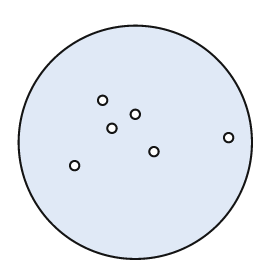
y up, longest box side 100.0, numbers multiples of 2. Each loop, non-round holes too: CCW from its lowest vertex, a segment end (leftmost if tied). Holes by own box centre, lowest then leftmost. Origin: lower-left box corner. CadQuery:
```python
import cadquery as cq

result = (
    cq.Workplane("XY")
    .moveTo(50.0, 50.0)
    .circle(50.0)
    .moveTo(24.0, 40.0)
    .circle(2.0)
    .moveTo(58.0, 46.0)
    .circle(2.0)
    .moveTo(90.0, 52.0)
    .circle(2.0)
    .moveTo(40.0, 56.0)
    .circle(2.0)
    .moveTo(50.0, 62.0)
    .circle(2.0)
    .moveTo(36.0, 68.0)
    .circle(2.0)
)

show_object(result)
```